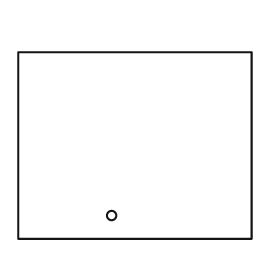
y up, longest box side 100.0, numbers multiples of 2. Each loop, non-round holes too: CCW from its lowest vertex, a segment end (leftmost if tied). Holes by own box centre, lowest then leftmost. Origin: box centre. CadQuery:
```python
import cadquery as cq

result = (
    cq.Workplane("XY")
    .moveTo(-50.0, -40.0)
    .lineTo(50.0, -40.0)
    .lineTo(50.0, 40.0)
    .lineTo(-50.0, 40.0)
    .close()
    .moveTo(-10.0, -30.0)
    .circle(2.0)
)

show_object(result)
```